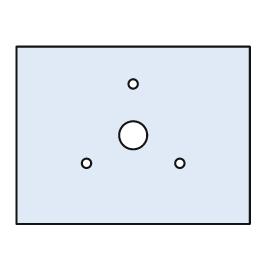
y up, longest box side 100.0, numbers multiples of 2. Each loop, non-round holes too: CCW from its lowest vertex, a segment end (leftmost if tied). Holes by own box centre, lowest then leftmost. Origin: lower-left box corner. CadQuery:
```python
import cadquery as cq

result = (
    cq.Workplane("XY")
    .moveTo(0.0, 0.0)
    .lineTo(100.0, 0.0)
    .lineTo(100.0, 76.0)
    .lineTo(0.0, 76.0)
    .close()
    .moveTo(30.0, 26.0)
    .circle(2.0)
    .moveTo(70.0, 26.0)
    .circle(2.0)
    .moveTo(50.0, 38.0)
    .circle(6.0)
    .moveTo(50.0, 60.0)
    .circle(2.0)
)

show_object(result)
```